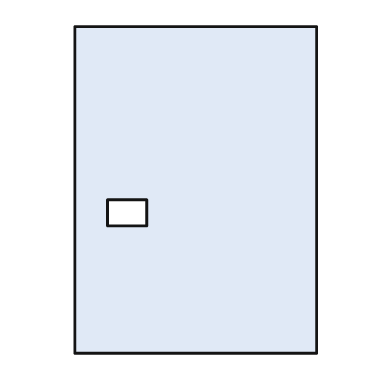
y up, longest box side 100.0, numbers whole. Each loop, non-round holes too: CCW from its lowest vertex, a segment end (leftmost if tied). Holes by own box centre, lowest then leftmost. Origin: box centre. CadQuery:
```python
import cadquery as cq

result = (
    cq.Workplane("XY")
    .moveTo(-37.0, -50.0)
    .lineTo(37.0, -50.0)
    .lineTo(37.0, 50.0)
    .lineTo(-37.0, 50.0)
    .close()
    .moveTo(-27.0, -11.0)
    .lineTo(-15.0, -11.0)
    .lineTo(-15.0, -3.0)
    .lineTo(-27.0, -3.0)
    .close()
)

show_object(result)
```